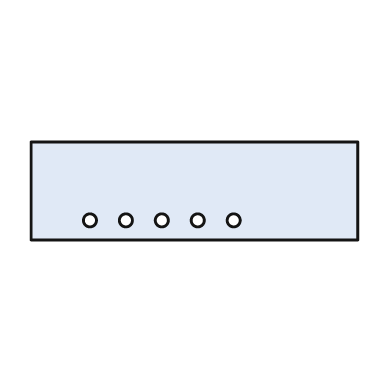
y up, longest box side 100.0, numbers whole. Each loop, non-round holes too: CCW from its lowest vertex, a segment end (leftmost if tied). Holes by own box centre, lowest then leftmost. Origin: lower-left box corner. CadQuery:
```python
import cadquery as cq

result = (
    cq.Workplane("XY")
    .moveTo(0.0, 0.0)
    .lineTo(100.0, 0.0)
    .lineTo(100.0, 30.0)
    .lineTo(0.0, 30.0)
    .close()
    .moveTo(18.0, 6.0)
    .circle(2.0)
    .moveTo(29.0, 6.0)
    .circle(2.0)
    .moveTo(40.0, 6.0)
    .circle(2.0)
    .moveTo(51.0, 6.0)
    .circle(2.0)
    .moveTo(62.0, 6.0)
    .circle(2.0)
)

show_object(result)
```